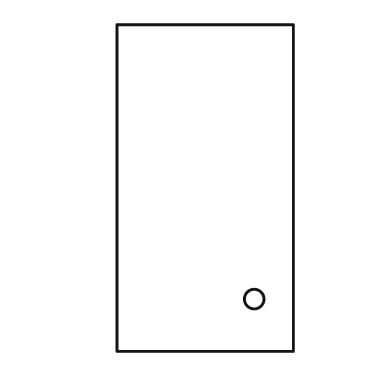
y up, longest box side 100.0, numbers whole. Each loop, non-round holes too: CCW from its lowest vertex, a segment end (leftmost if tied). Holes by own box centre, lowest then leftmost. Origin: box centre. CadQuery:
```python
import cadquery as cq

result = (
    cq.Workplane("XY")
    .moveTo(-27.0, -50.0)
    .lineTo(27.0, -50.0)
    .lineTo(27.0, 50.0)
    .lineTo(-27.0, 50.0)
    .close()
    .moveTo(15.0, -34.0)
    .circle(3.0)
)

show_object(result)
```